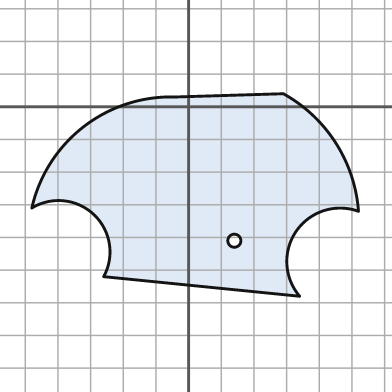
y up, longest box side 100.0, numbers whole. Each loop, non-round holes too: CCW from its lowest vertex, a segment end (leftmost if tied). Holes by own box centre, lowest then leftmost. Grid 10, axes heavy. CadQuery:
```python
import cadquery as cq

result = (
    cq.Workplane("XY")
    .moveTo(34.0, -58.0)
    .threePointArc((33.0, -38.0), (52.0, -32.0))
    .threePointArc((45.0, -11.0), (29.0, 4.0))
    .lineTo(-4.0, 3.0)
    .threePointArc((-32.0, -6.0), (-48.0, -31.0))
    .threePointArc((-29.0, -33.0), (-26.0, -52.0))
    .close()
    .moveTo(14.0, -41.0)
    .circle(2.0)
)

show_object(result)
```